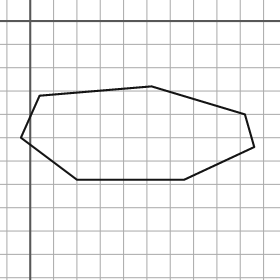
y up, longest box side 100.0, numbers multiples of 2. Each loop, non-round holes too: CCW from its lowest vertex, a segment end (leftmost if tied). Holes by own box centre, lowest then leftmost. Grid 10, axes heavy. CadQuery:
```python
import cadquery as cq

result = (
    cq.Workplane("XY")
    .moveTo(20.0, -68.0)
    .lineTo(66.0, -68.0)
    .lineTo(96.0, -54.0)
    .lineTo(92.0, -40.0)
    .lineTo(52.0, -28.0)
    .lineTo(4.0, -32.0)
    .lineTo(-4.0, -50.0)
    .close()
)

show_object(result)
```